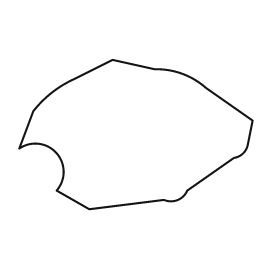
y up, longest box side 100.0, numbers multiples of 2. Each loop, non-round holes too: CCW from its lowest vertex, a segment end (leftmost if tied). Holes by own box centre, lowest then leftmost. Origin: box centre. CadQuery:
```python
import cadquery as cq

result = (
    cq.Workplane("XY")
    .moveTo(-20.0, -32.0)
    .lineTo(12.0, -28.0)
    .threePointArc((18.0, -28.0), (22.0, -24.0))
    .lineTo(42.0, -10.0)
    .threePointArc((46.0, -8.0), (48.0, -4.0))
    .lineTo(50.0, 6.0)
    .lineTo(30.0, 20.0)
    .threePointArc((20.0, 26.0), (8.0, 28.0))
    .lineTo(-10.0, 32.0)
    .lineTo(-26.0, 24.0)
    .threePointArc((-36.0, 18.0), (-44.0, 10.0))
    .lineTo(-50.0, -6.0)
    .threePointArc((-34.0, -8.0), (-34.0, -24.0))
    .close()
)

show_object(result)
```